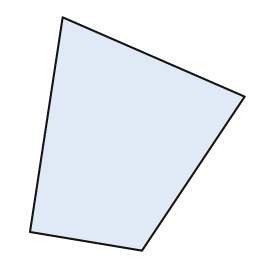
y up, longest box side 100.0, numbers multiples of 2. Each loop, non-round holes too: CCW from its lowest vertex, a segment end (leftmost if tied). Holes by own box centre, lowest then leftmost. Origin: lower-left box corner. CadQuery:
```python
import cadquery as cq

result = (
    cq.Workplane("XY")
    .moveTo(48.0, 0.0)
    .lineTo(92.0, 66.0)
    .lineTo(14.0, 100.0)
    .lineTo(0.0, 8.0)
    .close()
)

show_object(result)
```